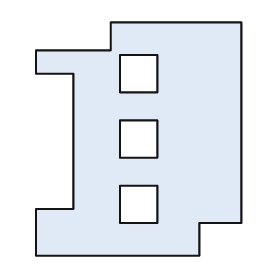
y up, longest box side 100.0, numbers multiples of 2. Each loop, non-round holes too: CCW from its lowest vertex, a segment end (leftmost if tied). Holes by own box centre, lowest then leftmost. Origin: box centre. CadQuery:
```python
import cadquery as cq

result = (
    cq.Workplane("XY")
    .moveTo(-44.0, -50.0)
    .lineTo(26.0, -50.0)
    .lineTo(26.0, -36.0)
    .lineTo(44.0, -36.0)
    .lineTo(44.0, 50.0)
    .lineTo(-12.0, 50.0)
    .lineTo(-12.0, 38.0)
    .lineTo(-44.0, 38.0)
    .lineTo(-44.0, 28.0)
    .lineTo(-28.0, 28.0)
    .lineTo(-28.0, -30.0)
    .lineTo(-44.0, -30.0)
    .close()
    .moveTo(-8.0, -36.0)
    .lineTo(8.0, -36.0)
    .lineTo(8.0, -20.0)
    .lineTo(-8.0, -20.0)
    .close()
    .moveTo(-8.0, -8.0)
    .lineTo(8.0, -8.0)
    .lineTo(8.0, 8.0)
    .lineTo(-8.0, 8.0)
    .close()
    .moveTo(-8.0, 20.0)
    .lineTo(8.0, 20.0)
    .lineTo(8.0, 36.0)
    .lineTo(-8.0, 36.0)
    .close()
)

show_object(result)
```